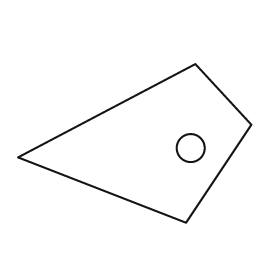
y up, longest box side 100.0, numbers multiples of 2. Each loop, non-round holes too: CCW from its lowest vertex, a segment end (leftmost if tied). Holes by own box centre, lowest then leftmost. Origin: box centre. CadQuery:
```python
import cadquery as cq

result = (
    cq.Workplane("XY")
    .moveTo(22.0, -34.0)
    .lineTo(50.0, 8.0)
    .lineTo(26.0, 34.0)
    .lineTo(-50.0, -6.0)
    .close()
    .moveTo(24.0, -2.0)
    .circle(6.0)
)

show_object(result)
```